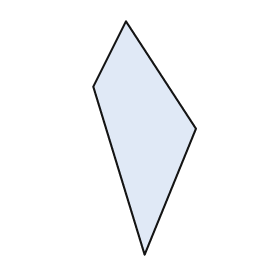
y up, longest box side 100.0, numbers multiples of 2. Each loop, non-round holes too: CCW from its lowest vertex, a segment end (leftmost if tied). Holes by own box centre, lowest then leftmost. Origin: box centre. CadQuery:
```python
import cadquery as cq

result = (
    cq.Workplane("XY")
    .moveTo(0.0, -50.0)
    .lineTo(22.0, 4.0)
    .lineTo(-8.0, 50.0)
    .lineTo(-22.0, 22.0)
    .close()
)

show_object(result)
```